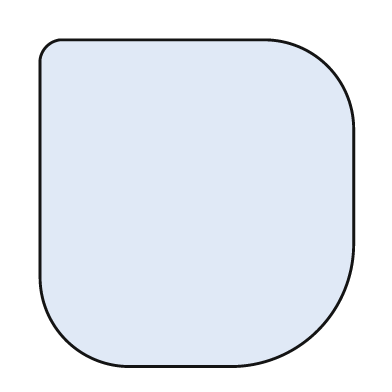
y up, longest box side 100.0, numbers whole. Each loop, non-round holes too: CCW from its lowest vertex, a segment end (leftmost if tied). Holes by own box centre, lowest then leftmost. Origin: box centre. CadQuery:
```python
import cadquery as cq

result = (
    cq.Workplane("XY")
    .moveTo(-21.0, -50.0)
    .lineTo(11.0, -50.0)
    .threePointArc((37.0, -39.0), (48.0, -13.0))
    .lineTo(48.0, 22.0)
    .threePointArc((40.0, 42.0), (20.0, 50.0))
    .lineTo(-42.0, 50.0)
    .threePointArc((-46.0, 48.0), (-48.0, 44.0))
    .lineTo(-48.0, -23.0)
    .threePointArc((-40.0, -42.0), (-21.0, -50.0))
    .close()
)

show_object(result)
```